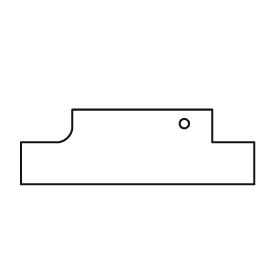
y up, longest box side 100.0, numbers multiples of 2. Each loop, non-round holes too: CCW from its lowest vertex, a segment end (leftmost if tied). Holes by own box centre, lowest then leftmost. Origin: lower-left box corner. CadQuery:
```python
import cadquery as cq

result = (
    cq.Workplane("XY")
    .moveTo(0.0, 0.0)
    .lineTo(100.0, 0.0)
    .lineTo(100.0, 18.0)
    .lineTo(82.0, 18.0)
    .lineTo(82.0, 32.0)
    .lineTo(22.0, 32.0)
    .lineTo(22.0, 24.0)
    .threePointArc((20.0, 20.0), (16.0, 18.0))
    .lineTo(0.0, 18.0)
    .close()
    .moveTo(70.0, 26.0)
    .circle(2.0)
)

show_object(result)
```